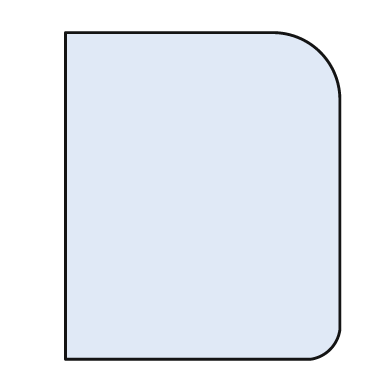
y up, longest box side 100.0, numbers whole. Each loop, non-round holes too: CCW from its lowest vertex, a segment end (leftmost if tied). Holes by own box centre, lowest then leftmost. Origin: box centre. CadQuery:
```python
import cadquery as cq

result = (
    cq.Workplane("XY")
    .moveTo(-42.0, -50.0)
    .lineTo(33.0, -50.0)
    .threePointArc((39.0, -47.0), (42.0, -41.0))
    .lineTo(42.0, 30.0)
    .threePointArc((36.0, 44.0), (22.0, 50.0))
    .lineTo(-42.0, 50.0)
    .close()
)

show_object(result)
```